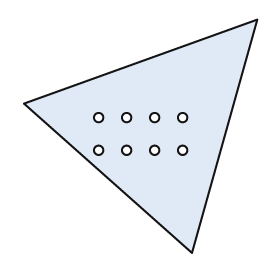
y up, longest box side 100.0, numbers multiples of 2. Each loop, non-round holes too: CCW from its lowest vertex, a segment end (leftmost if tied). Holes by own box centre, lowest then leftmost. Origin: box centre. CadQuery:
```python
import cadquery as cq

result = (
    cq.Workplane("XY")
    .moveTo(22.0, -50.0)
    .lineTo(50.0, 50.0)
    .lineTo(-50.0, 14.0)
    .close()
    .moveTo(-18.0, -6.0)
    .circle(2.0)
    .moveTo(-6.0, -6.0)
    .circle(2.0)
    .moveTo(6.0, -6.0)
    .circle(2.0)
    .moveTo(18.0, -6.0)
    .circle(2.0)
    .moveTo(-18.0, 8.0)
    .circle(2.0)
    .moveTo(-6.0, 8.0)
    .circle(2.0)
    .moveTo(6.0, 8.0)
    .circle(2.0)
    .moveTo(18.0, 8.0)
    .circle(2.0)
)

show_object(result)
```